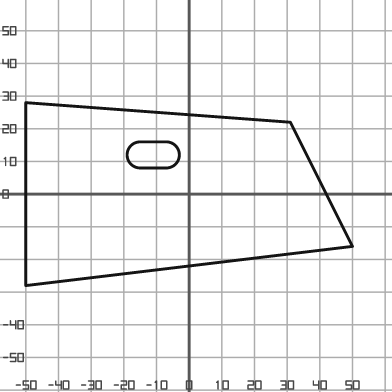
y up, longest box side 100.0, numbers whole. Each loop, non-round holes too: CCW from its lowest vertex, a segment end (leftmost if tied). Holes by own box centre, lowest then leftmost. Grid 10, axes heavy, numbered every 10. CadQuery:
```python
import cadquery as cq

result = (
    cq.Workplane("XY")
    .moveTo(-50.0, -28.0)
    .lineTo(50.0, -16.0)
    .lineTo(31.0, 22.0)
    .lineTo(-50.0, 28.0)
    .close()
    .moveTo(-15.0, 8.0)
    .lineTo(-7.0, 8.0)
    .threePointArc((-3.0, 12.0), (-7.0, 16.0))
    .lineTo(-15.0, 16.0)
    .threePointArc((-19.0, 12.0), (-15.0, 8.0))
    .close()
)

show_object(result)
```